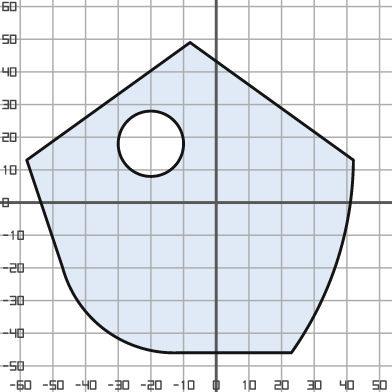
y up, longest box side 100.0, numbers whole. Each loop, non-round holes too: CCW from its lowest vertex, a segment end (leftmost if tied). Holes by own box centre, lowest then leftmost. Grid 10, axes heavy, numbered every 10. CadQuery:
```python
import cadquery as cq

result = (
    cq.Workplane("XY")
    .moveTo(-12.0, -46.0)
    .lineTo(23.0, -46.0)
    .threePointArc((37.0, -18.0), (42.0, 13.0))
    .lineTo(-8.0, 49.0)
    .lineTo(-58.0, 13.0)
    .lineTo(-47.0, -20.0)
    .threePointArc((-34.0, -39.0), (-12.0, -46.0))
    .close()
    .moveTo(-20.0, 18.0)
    .circle(10.0)
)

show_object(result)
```